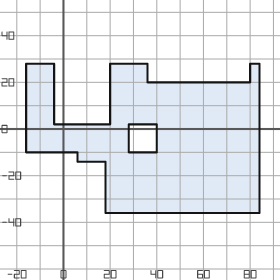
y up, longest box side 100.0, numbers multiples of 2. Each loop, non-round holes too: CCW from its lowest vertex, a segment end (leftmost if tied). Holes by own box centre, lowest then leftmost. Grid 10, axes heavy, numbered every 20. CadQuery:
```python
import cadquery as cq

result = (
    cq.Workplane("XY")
    .moveTo(18.0, -36.0)
    .lineTo(84.0, -36.0)
    .lineTo(84.0, 28.0)
    .lineTo(80.0, 28.0)
    .lineTo(80.0, 20.0)
    .lineTo(36.0, 20.0)
    .lineTo(36.0, 28.0)
    .lineTo(20.0, 28.0)
    .lineTo(20.0, 2.0)
    .lineTo(-4.0, 2.0)
    .lineTo(-4.0, 28.0)
    .lineTo(-16.0, 28.0)
    .lineTo(-16.0, -10.0)
    .lineTo(6.0, -10.0)
    .lineTo(6.0, -14.0)
    .lineTo(18.0, -14.0)
    .close()
    .moveTo(28.0, -10.0)
    .lineTo(40.0, -10.0)
    .lineTo(40.0, 2.0)
    .lineTo(28.0, 2.0)
    .close()
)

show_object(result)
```